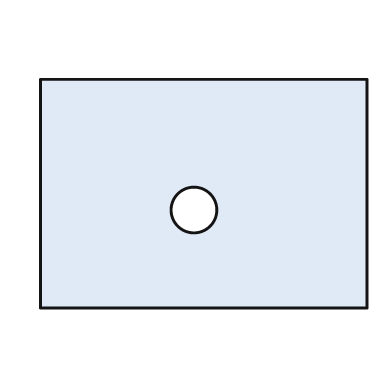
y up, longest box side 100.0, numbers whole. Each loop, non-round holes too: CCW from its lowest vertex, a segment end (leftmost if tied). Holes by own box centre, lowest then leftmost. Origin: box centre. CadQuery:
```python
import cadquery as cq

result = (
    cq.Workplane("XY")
    .moveTo(-50.0, -35.0)
    .lineTo(50.0, -35.0)
    .lineTo(50.0, 35.0)
    .lineTo(-50.0, 35.0)
    .close()
    .moveTo(-3.0, -5.0)
    .circle(7.0)
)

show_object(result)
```